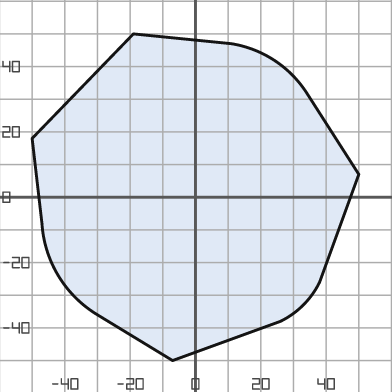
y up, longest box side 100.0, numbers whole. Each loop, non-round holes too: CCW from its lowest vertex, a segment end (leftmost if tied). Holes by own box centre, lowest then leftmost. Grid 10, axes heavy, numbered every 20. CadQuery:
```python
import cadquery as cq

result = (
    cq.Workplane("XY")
    .moveTo(-7.0, -50.0)
    .lineTo(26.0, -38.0)
    .threePointArc((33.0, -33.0), (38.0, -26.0))
    .lineTo(50.0, 7.0)
    .lineTo(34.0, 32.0)
    .threePointArc((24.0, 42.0), (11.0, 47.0))
    .lineTo(-19.0, 50.0)
    .lineTo(-50.0, 18.0)
    .lineTo(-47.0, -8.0)
    .threePointArc((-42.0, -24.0), (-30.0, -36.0))
    .close()
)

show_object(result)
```